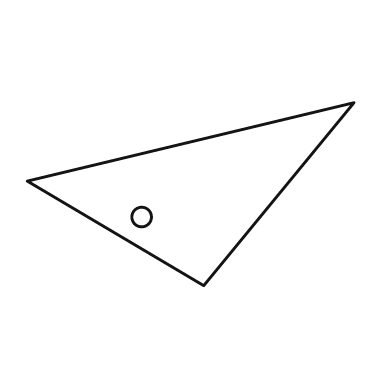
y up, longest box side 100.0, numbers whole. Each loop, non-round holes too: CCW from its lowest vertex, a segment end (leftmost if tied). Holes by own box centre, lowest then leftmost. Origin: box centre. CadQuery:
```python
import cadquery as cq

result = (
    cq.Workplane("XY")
    .moveTo(4.0, -28.0)
    .lineTo(50.0, 28.0)
    .lineTo(-50.0, 4.0)
    .close()
    .moveTo(-15.0, -7.0)
    .circle(3.0)
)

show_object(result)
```